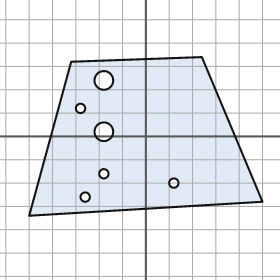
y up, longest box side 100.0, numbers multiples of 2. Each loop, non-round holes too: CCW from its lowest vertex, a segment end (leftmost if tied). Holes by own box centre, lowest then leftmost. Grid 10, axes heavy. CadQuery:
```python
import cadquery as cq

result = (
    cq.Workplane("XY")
    .moveTo(-50.0, -34.0)
    .lineTo(50.0, -28.0)
    .lineTo(24.0, 34.0)
    .lineTo(-32.0, 32.0)
    .close()
    .moveTo(-26.0, -26.0)
    .circle(2.0)
    .moveTo(12.0, -20.0)
    .circle(2.0)
    .moveTo(-18.0, -16.0)
    .circle(2.0)
    .moveTo(-18.0, 2.0)
    .circle(4.0)
    .moveTo(-28.0, 12.0)
    .circle(2.0)
    .moveTo(-18.0, 24.0)
    .circle(4.0)
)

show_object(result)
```